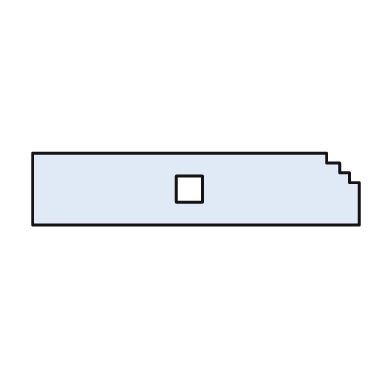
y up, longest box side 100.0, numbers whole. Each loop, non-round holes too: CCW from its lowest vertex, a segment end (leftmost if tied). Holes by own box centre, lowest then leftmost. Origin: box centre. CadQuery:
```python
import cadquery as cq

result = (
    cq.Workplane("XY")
    .moveTo(-50.0, -11.0)
    .lineTo(50.0, -11.0)
    .lineTo(50.0, 2.0)
    .lineTo(47.0, 2.0)
    .lineTo(47.0, 5.0)
    .lineTo(44.0, 5.0)
    .lineTo(44.0, 8.0)
    .lineTo(40.0, 8.0)
    .lineTo(40.0, 11.0)
    .lineTo(-50.0, 11.0)
    .close()
    .moveTo(-6.0, -4.0)
    .lineTo(2.0, -4.0)
    .lineTo(2.0, 4.0)
    .lineTo(-6.0, 4.0)
    .close()
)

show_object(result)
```